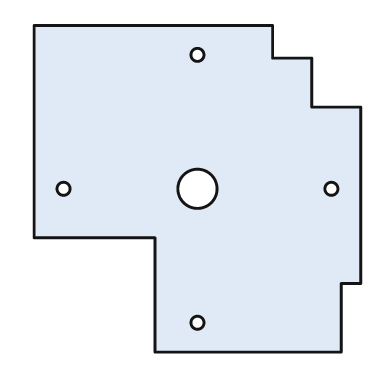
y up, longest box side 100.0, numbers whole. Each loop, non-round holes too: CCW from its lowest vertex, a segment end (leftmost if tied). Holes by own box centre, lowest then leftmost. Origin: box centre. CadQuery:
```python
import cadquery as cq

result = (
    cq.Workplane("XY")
    .moveTo(-13.0, -50.0)
    .lineTo(44.0, -50.0)
    .lineTo(44.0, -29.0)
    .lineTo(50.0, -29.0)
    .lineTo(50.0, 25.0)
    .lineTo(35.0, 25.0)
    .lineTo(35.0, 40.0)
    .lineTo(23.0, 40.0)
    .lineTo(23.0, 50.0)
    .lineTo(-50.0, 50.0)
    .lineTo(-50.0, -15.0)
    .lineTo(-13.0, -15.0)
    .close()
    .moveTo(0.0, -41.0)
    .circle(2.0)
    .moveTo(-41.0, 0.0)
    .circle(2.0)
    .moveTo(0.0, 0.0)
    .circle(6.0)
    .moveTo(41.0, 0.0)
    .circle(2.0)
    .moveTo(0.0, 41.0)
    .circle(2.0)
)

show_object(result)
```